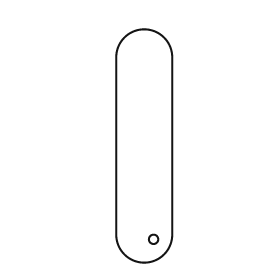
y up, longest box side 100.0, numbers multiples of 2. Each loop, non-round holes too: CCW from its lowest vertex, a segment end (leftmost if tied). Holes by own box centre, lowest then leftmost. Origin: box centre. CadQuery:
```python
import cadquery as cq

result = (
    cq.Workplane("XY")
    .moveTo(-12.0, -38.0)
    .threePointArc((0.0, -50.0), (12.0, -38.0))
    .lineTo(12.0, 38.0)
    .threePointArc((0.0, 50.0), (-12.0, 38.0))
    .close()
    .moveTo(4.0, -40.0)
    .circle(2.0)
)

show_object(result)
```